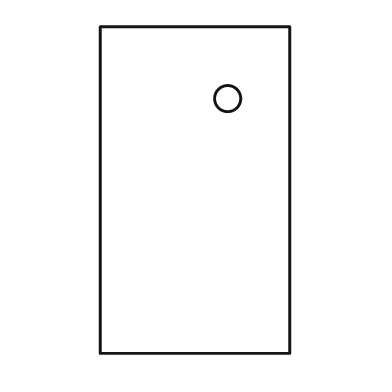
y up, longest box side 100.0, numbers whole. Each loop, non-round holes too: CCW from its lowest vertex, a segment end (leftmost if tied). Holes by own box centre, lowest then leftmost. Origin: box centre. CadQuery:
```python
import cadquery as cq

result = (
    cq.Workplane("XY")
    .moveTo(-29.0, -50.0)
    .lineTo(29.0, -50.0)
    .lineTo(29.0, 50.0)
    .lineTo(-29.0, 50.0)
    .close()
    .moveTo(10.0, 28.0)
    .circle(4.0)
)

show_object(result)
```